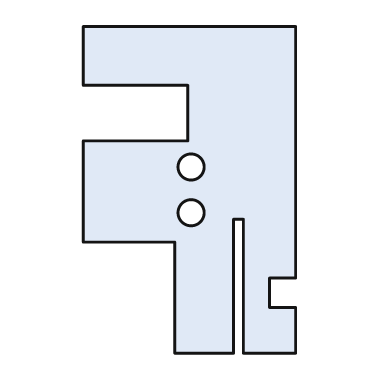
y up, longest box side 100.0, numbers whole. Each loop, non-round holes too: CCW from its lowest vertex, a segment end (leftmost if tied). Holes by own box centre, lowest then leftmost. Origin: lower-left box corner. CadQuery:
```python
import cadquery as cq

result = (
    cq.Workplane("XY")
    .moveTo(28.0, 0.0)
    .lineTo(46.0, 0.0)
    .lineTo(46.0, 41.0)
    .lineTo(49.0, 41.0)
    .lineTo(49.0, 0.0)
    .lineTo(65.0, 0.0)
    .lineTo(65.0, 14.0)
    .lineTo(57.0, 14.0)
    .lineTo(57.0, 23.0)
    .lineTo(65.0, 23.0)
    .lineTo(65.0, 100.0)
    .lineTo(0.0, 100.0)
    .lineTo(0.0, 82.0)
    .lineTo(32.0, 82.0)
    .lineTo(32.0, 65.0)
    .lineTo(0.0, 65.0)
    .lineTo(0.0, 34.0)
    .lineTo(28.0, 34.0)
    .close()
    .moveTo(33.0, 43.0)
    .circle(4.0)
    .moveTo(33.0, 57.0)
    .circle(4.0)
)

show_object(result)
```